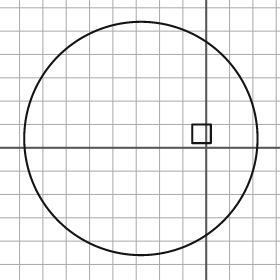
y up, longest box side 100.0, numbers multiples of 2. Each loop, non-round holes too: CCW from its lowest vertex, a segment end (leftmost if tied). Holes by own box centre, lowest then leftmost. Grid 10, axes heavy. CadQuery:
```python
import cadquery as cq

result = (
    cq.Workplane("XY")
    .moveTo(-28.0, 4.0)
    .circle(50.0)
    .moveTo(-6.0, 2.0)
    .lineTo(2.0, 2.0)
    .lineTo(2.0, 10.0)
    .lineTo(-6.0, 10.0)
    .close()
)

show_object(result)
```